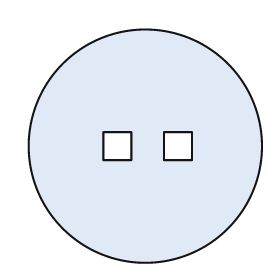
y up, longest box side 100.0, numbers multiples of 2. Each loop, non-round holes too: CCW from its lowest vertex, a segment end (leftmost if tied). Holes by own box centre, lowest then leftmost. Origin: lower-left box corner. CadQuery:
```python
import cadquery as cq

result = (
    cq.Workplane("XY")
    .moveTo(50.0, 50.0)
    .circle(50.0)
    .moveTo(32.0, 44.0)
    .lineTo(44.0, 44.0)
    .lineTo(44.0, 56.0)
    .lineTo(32.0, 56.0)
    .close()
    .moveTo(58.0, 44.0)
    .lineTo(70.0, 44.0)
    .lineTo(70.0, 56.0)
    .lineTo(58.0, 56.0)
    .close()
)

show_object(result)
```